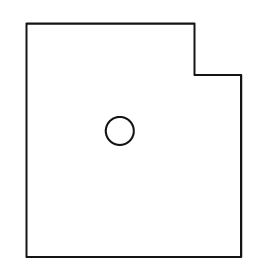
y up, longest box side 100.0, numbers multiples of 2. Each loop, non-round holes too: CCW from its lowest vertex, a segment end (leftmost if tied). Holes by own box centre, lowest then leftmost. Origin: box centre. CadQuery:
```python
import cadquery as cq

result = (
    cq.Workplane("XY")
    .moveTo(-46.0, -50.0)
    .lineTo(46.0, -50.0)
    .lineTo(46.0, 28.0)
    .lineTo(26.0, 28.0)
    .lineTo(26.0, 50.0)
    .lineTo(-46.0, 50.0)
    .close()
    .moveTo(-6.0, 4.0)
    .circle(6.0)
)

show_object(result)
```